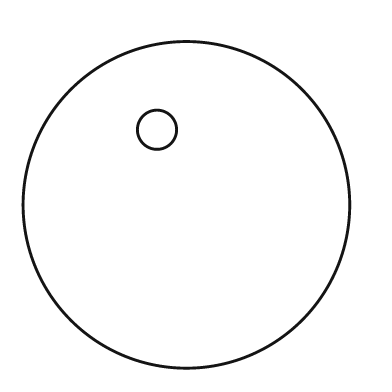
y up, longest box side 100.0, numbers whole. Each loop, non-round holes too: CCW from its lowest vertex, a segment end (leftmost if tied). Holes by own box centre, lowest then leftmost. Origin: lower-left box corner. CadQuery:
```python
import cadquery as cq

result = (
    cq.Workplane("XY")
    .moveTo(50.0, 50.0)
    .circle(50.0)
    .moveTo(41.0, 73.0)
    .circle(6.0)
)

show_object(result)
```